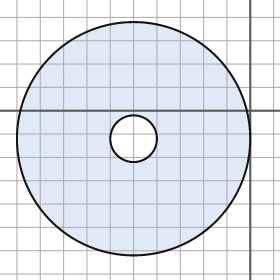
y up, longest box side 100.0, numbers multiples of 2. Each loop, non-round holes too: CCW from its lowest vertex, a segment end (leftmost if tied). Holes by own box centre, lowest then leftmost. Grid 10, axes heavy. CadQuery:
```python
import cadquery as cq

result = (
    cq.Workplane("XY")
    .moveTo(-50.0, -12.0)
    .circle(50.0)
    .moveTo(-50.0, -12.0)
    .circle(10.0)
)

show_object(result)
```